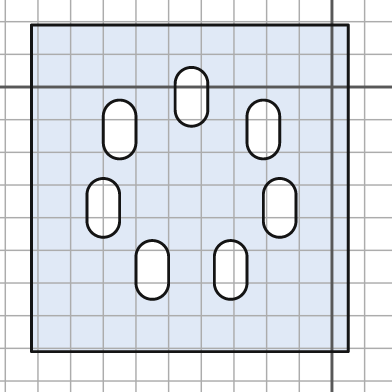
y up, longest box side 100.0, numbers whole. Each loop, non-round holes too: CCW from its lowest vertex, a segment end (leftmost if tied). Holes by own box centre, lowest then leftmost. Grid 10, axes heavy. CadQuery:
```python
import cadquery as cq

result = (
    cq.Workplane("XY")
    .moveTo(-92.0, -81.0)
    .lineTo(5.0, -81.0)
    .lineTo(5.0, 19.0)
    .lineTo(-92.0, 19.0)
    .close()
    .moveTo(-60.0, -60.0)
    .threePointArc((-55.0, -65.0), (-50.0, -60.0))
    .lineTo(-50.0, -52.0)
    .threePointArc((-55.0, -47.0), (-60.0, -52.0))
    .close()
    .moveTo(-36.0, -60.0)
    .threePointArc((-31.0, -65.0), (-26.0, -60.0))
    .lineTo(-26.0, -52.0)
    .threePointArc((-31.0, -47.0), (-36.0, -52.0))
    .close()
    .moveTo(-75.0, -41.0)
    .threePointArc((-70.0, -46.0), (-65.0, -41.0))
    .lineTo(-65.0, -33.0)
    .threePointArc((-70.0, -28.0), (-75.0, -33.0))
    .close()
    .moveTo(-21.0, -41.0)
    .threePointArc((-16.0, -46.0), (-11.0, -41.0))
    .lineTo(-11.0, -33.0)
    .threePointArc((-16.0, -28.0), (-21.0, -33.0))
    .close()
    .moveTo(-70.0, -17.0)
    .threePointArc((-65.0, -22.0), (-60.0, -17.0))
    .lineTo(-60.0, -9.0)
    .threePointArc((-65.0, -4.0), (-70.0, -9.0))
    .close()
    .moveTo(-26.0, -17.0)
    .threePointArc((-21.0, -22.0), (-16.0, -17.0))
    .lineTo(-16.0, -9.0)
    .threePointArc((-21.0, -4.0), (-26.0, -9.0))
    .close()
    .moveTo(-48.0, -7.0)
    .threePointArc((-43.0, -12.0), (-38.0, -7.0))
    .lineTo(-38.0, 1.0)
    .threePointArc((-43.0, 6.0), (-48.0, 1.0))
    .close()
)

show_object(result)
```